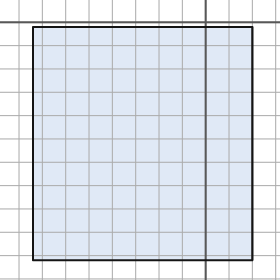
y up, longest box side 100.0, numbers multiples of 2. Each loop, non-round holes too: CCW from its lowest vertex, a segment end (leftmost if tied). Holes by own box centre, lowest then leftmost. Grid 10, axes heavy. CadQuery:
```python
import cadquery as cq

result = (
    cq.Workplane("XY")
    .moveTo(-74.0, -102.0)
    .lineTo(20.0, -102.0)
    .lineTo(20.0, -2.0)
    .lineTo(-74.0, -2.0)
    .close()
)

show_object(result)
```